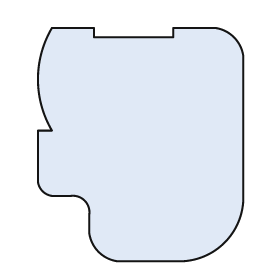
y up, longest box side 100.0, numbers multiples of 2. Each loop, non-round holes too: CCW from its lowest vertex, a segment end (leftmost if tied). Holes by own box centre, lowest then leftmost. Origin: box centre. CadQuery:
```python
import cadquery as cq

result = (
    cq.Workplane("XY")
    .moveTo(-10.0, -50.0)
    .lineTo(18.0, -50.0)
    .threePointArc((36.0, -42.0), (44.0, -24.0))
    .lineTo(44.0, 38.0)
    .threePointArc((40.0, 46.0), (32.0, 50.0))
    .lineTo(14.0, 50.0)
    .lineTo(14.0, 46.0)
    .lineTo(-20.0, 46.0)
    .lineTo(-20.0, 50.0)
    .lineTo(-38.0, 50.0)
    .threePointArc((-44.0, 28.0), (-38.0, 6.0))
    .lineTo(-44.0, 6.0)
    .lineTo(-44.0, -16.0)
    .threePointArc((-42.0, -20.0), (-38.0, -22.0))
    .lineTo(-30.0, -22.0)
    .threePointArc((-24.0, -24.0), (-22.0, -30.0))
    .lineTo(-22.0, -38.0)
    .threePointArc((-18.0, -46.0), (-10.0, -50.0))
    .close()
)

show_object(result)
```